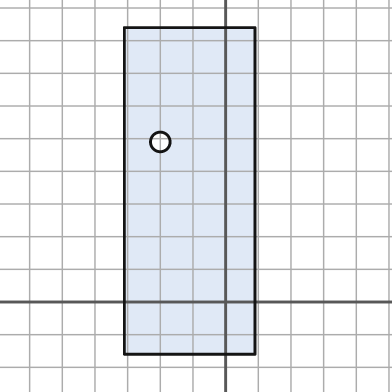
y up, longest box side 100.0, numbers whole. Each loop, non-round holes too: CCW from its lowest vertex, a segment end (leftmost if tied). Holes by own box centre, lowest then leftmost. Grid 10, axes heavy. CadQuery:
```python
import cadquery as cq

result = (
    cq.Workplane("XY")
    .moveTo(-31.0, -16.0)
    .lineTo(9.0, -16.0)
    .lineTo(9.0, 84.0)
    .lineTo(-31.0, 84.0)
    .close()
    .moveTo(-20.0, 49.0)
    .circle(3.0)
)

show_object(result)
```